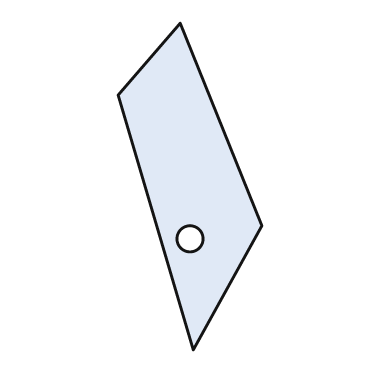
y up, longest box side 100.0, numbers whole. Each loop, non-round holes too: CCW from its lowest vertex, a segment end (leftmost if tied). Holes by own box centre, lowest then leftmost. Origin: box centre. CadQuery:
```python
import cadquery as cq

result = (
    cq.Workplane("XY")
    .moveTo(1.0, -50.0)
    .lineTo(22.0, -12.0)
    .lineTo(-3.0, 50.0)
    .lineTo(-22.0, 28.0)
    .close()
    .moveTo(0.0, -16.0)
    .circle(4.0)
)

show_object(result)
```